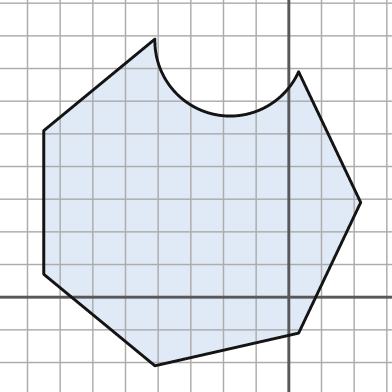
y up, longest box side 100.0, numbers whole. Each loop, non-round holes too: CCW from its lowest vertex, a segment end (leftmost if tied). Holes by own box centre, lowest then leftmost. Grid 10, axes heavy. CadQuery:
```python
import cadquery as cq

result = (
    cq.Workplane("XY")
    .moveTo(-41.0, -21.0)
    .lineTo(3.0, -11.0)
    .lineTo(22.0, 29.0)
    .lineTo(3.0, 69.0)
    .threePointArc((-23.0, 56.0), (-41.0, 79.0))
    .lineTo(-75.0, 51.0)
    .lineTo(-75.0, 7.0)
    .close()
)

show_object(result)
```